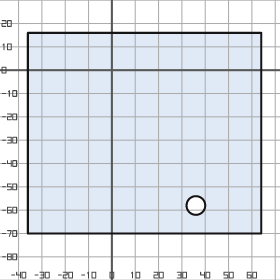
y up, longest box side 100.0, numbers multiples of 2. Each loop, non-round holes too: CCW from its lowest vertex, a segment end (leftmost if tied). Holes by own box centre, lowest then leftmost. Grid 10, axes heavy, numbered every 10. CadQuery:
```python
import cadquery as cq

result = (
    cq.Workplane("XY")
    .moveTo(-36.0, -70.0)
    .lineTo(64.0, -70.0)
    .lineTo(64.0, 16.0)
    .lineTo(-36.0, 16.0)
    .close()
    .moveTo(36.0, -58.0)
    .circle(4.0)
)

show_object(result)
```